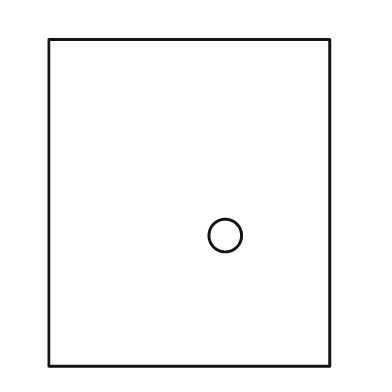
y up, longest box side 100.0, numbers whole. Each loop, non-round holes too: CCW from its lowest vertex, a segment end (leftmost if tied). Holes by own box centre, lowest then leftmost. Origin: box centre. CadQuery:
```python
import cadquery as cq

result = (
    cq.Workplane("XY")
    .moveTo(-43.0, -50.0)
    .lineTo(43.0, -50.0)
    .lineTo(43.0, 50.0)
    .lineTo(-43.0, 50.0)
    .close()
    .moveTo(11.0, -10.0)
    .circle(5.0)
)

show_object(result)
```